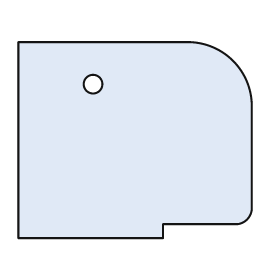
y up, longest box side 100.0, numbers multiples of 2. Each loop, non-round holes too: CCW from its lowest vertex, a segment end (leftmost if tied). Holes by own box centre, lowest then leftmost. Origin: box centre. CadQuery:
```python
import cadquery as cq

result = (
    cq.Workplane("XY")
    .moveTo(-50.0, -42.0)
    .lineTo(12.0, -42.0)
    .lineTo(12.0, -36.0)
    .lineTo(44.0, -36.0)
    .threePointArc((48.0, -34.0), (50.0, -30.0))
    .lineTo(50.0, 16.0)
    .threePointArc((42.0, 34.0), (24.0, 42.0))
    .lineTo(-50.0, 42.0)
    .close()
    .moveTo(-18.0, 24.0)
    .circle(4.0)
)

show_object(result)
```